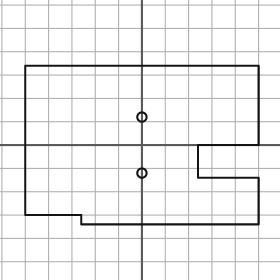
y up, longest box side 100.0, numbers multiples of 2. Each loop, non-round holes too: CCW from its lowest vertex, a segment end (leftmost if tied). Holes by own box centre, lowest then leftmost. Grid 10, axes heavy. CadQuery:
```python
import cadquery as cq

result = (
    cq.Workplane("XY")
    .moveTo(-26.0, -34.0)
    .lineTo(50.0, -34.0)
    .lineTo(50.0, -14.0)
    .lineTo(24.0, -14.0)
    .lineTo(24.0, 0.0)
    .lineTo(50.0, 0.0)
    .lineTo(50.0, 34.0)
    .lineTo(-50.0, 34.0)
    .lineTo(-50.0, -30.0)
    .lineTo(-26.0, -30.0)
    .close()
    .moveTo(0.0, -12.0)
    .circle(2.0)
    .moveTo(0.0, 12.0)
    .circle(2.0)
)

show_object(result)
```